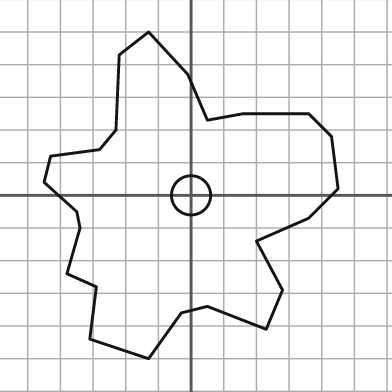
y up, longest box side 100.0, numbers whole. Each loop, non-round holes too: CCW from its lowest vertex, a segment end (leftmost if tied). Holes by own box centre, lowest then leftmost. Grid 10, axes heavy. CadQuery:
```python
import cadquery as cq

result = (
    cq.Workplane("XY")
    .moveTo(-13.0, -50.0)
    .lineTo(-3.0, -36.0)
    .lineTo(5.0, -34.0)
    .lineTo(23.0, -41.0)
    .lineTo(28.0, -29.0)
    .lineTo(20.0, -14.0)
    .lineTo(36.0, -7.0)
    .lineTo(45.0, 2.0)
    .lineTo(43.0, 18.0)
    .lineTo(36.0, 25.0)
    .lineTo(16.0, 25.0)
    .lineTo(5.0, 23.0)
    .lineTo(-1.0, 37.0)
    .lineTo(-13.0, 50.0)
    .lineTo(-22.0, 43.0)
    .lineTo(-23.0, 20.0)
    .lineTo(-28.0, 14.0)
    .lineTo(-43.0, 12.0)
    .lineTo(-45.0, 4.0)
    .lineTo(-35.0, -5.0)
    .lineTo(-34.0, -10.0)
    .lineTo(-38.0, -24.0)
    .lineTo(-29.0, -28.0)
    .lineTo(-31.0, -44.0)
    .close()
    .moveTo(0.0, 0.0)
    .circle(6.0)
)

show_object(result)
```